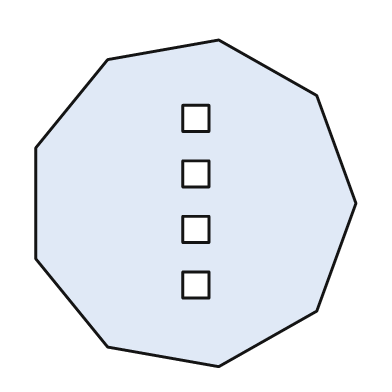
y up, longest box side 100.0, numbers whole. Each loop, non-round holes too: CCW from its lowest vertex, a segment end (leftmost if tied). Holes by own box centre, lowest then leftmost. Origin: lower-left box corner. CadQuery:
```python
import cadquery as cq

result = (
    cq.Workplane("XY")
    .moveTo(56.0, 0.0)
    .lineTo(86.0, 17.0)
    .lineTo(98.0, 50.0)
    .lineTo(86.0, 83.0)
    .lineTo(56.0, 100.0)
    .lineTo(22.0, 94.0)
    .lineTo(0.0, 67.0)
    .lineTo(0.0, 33.0)
    .lineTo(22.0, 6.0)
    .close()
    .moveTo(45.0, 21.0)
    .lineTo(53.0, 21.0)
    .lineTo(53.0, 29.0)
    .lineTo(45.0, 29.0)
    .close()
    .moveTo(45.0, 38.0)
    .lineTo(53.0, 38.0)
    .lineTo(53.0, 46.0)
    .lineTo(45.0, 46.0)
    .close()
    .moveTo(45.0, 55.0)
    .lineTo(53.0, 55.0)
    .lineTo(53.0, 63.0)
    .lineTo(45.0, 63.0)
    .close()
    .moveTo(45.0, 72.0)
    .lineTo(53.0, 72.0)
    .lineTo(53.0, 80.0)
    .lineTo(45.0, 80.0)
    .close()
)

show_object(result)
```